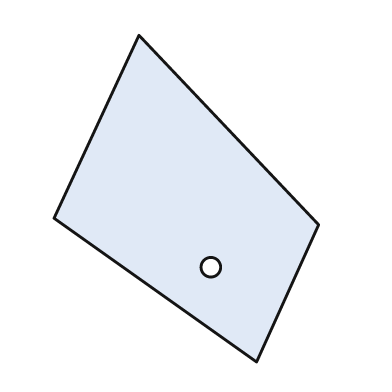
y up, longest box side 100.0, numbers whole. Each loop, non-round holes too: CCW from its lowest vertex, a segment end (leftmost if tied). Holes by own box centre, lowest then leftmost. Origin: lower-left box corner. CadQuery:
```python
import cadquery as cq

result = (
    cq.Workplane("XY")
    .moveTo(62.0, 0.0)
    .lineTo(81.0, 42.0)
    .lineTo(26.0, 100.0)
    .lineTo(0.0, 44.0)
    .close()
    .moveTo(48.0, 29.0)
    .circle(3.0)
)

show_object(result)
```